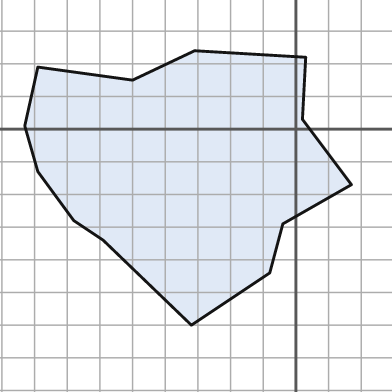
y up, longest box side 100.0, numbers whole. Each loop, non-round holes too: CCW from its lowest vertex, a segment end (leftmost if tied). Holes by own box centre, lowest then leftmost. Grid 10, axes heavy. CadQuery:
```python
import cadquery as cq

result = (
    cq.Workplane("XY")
    .moveTo(-32.0, -60.0)
    .lineTo(-8.0, -44.0)
    .lineTo(-4.0, -29.0)
    .lineTo(17.0, -17.0)
    .lineTo(2.0, 3.0)
    .lineTo(3.0, 22.0)
    .lineTo(-31.0, 24.0)
    .lineTo(-50.0, 15.0)
    .lineTo(-79.0, 19.0)
    .lineTo(-83.0, 1.0)
    .lineTo(-79.0, -13.0)
    .lineTo(-68.0, -28.0)
    .lineTo(-59.0, -34.0)
    .close()
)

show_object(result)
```